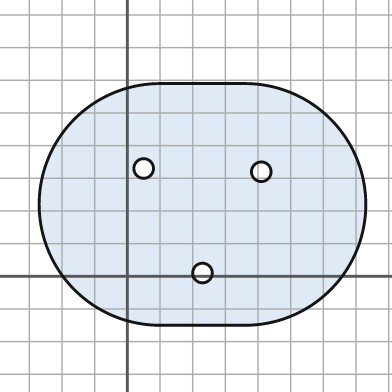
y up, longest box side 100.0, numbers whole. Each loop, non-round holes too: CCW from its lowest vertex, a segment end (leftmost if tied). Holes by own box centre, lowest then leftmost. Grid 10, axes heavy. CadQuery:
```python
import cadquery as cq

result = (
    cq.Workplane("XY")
    .moveTo(10.0, -15.0)
    .lineTo(36.0, -15.0)
    .threePointArc((73.0, 22.0), (36.0, 59.0))
    .lineTo(10.0, 59.0)
    .threePointArc((-27.0, 22.0), (10.0, -15.0))
    .close()
    .moveTo(23.0, 1.0)
    .circle(3.0)
    .moveTo(41.0, 32.0)
    .circle(3.0)
    .moveTo(5.0, 33.0)
    .circle(3.0)
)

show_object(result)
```